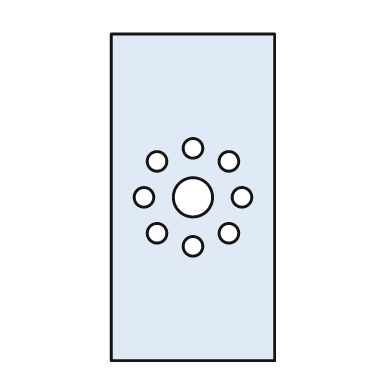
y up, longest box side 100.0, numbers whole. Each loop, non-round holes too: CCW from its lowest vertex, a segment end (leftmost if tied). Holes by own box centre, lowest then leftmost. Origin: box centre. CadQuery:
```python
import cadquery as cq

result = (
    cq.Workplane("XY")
    .moveTo(-25.0, -50.0)
    .lineTo(25.0, -50.0)
    .lineTo(25.0, 50.0)
    .lineTo(-25.0, 50.0)
    .close()
    .moveTo(0.0, -15.0)
    .circle(3.0)
    .moveTo(-11.0, -11.0)
    .circle(3.0)
    .moveTo(11.0, -11.0)
    .circle(3.0)
    .moveTo(-15.0, 0.0)
    .circle(3.0)
    .moveTo(0.0, 0.0)
    .circle(6.0)
    .moveTo(15.0, 0.0)
    .circle(3.0)
    .moveTo(-11.0, 11.0)
    .circle(3.0)
    .moveTo(11.0, 11.0)
    .circle(3.0)
    .moveTo(0.0, 15.0)
    .circle(3.0)
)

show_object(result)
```